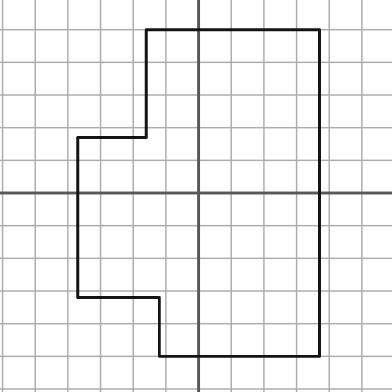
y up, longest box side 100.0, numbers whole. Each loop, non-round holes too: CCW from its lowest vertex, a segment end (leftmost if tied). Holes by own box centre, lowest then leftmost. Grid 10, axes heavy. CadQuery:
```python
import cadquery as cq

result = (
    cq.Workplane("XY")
    .moveTo(-12.0, -50.0)
    .lineTo(37.0, -50.0)
    .lineTo(37.0, 50.0)
    .lineTo(-16.0, 50.0)
    .lineTo(-16.0, 17.0)
    .lineTo(-37.0, 17.0)
    .lineTo(-37.0, -32.0)
    .lineTo(-12.0, -32.0)
    .close()
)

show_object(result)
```